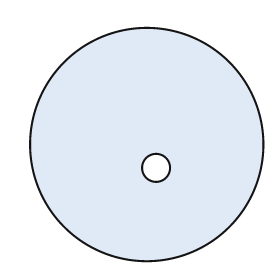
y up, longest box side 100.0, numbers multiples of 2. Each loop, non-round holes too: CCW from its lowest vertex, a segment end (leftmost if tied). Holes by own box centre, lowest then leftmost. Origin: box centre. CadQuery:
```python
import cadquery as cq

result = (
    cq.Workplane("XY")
    .moveTo(0.0, 0.0)
    .circle(50.0)
    .moveTo(4.0, -10.0)
    .circle(6.0)
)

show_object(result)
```